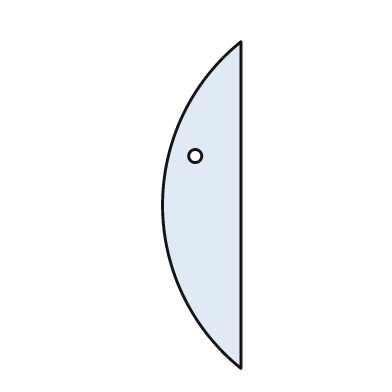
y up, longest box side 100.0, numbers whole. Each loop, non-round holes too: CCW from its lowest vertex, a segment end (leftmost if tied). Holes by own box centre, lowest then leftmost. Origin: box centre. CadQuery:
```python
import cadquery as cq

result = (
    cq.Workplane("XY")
    .moveTo(12.0, -50.0)
    .lineTo(12.0, 50.0)
    .threePointArc((-12.0, 0.0), (12.0, -50.0))
    .close()
    .moveTo(-2.0, 15.0)
    .circle(2.0)
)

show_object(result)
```